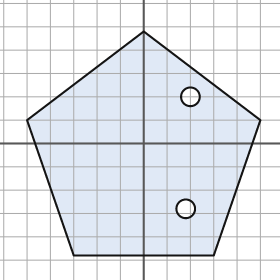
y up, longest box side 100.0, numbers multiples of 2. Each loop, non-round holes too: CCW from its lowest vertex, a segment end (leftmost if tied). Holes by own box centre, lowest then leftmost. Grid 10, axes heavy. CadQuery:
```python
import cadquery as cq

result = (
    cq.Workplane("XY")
    .moveTo(-30.0, -48.0)
    .lineTo(30.0, -48.0)
    .lineTo(50.0, 10.0)
    .lineTo(0.0, 48.0)
    .lineTo(-50.0, 10.0)
    .close()
    .moveTo(18.0, -28.0)
    .circle(4.0)
    .moveTo(20.0, 20.0)
    .circle(4.0)
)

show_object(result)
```